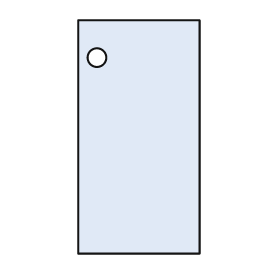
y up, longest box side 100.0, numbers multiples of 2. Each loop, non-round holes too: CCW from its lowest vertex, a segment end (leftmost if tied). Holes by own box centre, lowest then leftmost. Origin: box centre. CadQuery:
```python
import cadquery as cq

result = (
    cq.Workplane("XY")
    .moveTo(-26.0, -50.0)
    .lineTo(26.0, -50.0)
    .lineTo(26.0, 50.0)
    .lineTo(-26.0, 50.0)
    .close()
    .moveTo(-18.0, 34.0)
    .circle(4.0)
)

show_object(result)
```